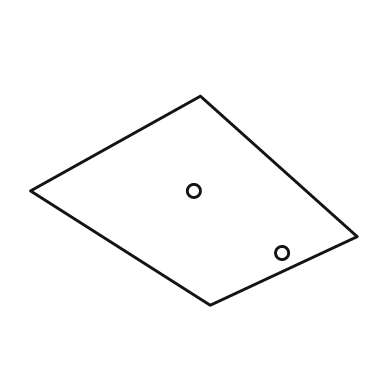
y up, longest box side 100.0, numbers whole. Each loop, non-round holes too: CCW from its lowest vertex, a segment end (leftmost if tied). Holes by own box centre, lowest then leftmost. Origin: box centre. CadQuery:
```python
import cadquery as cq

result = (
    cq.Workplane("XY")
    .moveTo(5.0, -32.0)
    .lineTo(50.0, -11.0)
    .lineTo(2.0, 32.0)
    .lineTo(-50.0, 3.0)
    .close()
    .moveTo(27.0, -16.0)
    .circle(2.0)
    .moveTo(0.0, 3.0)
    .circle(2.0)
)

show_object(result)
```